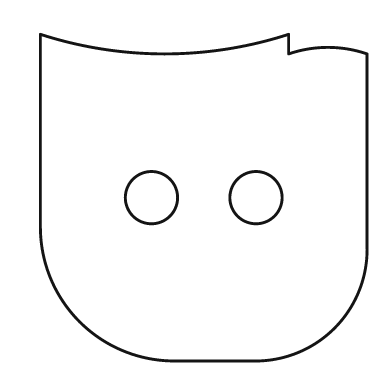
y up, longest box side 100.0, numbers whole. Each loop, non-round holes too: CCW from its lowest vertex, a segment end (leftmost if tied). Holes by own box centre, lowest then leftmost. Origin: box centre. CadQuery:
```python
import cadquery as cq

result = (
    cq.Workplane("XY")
    .moveTo(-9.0, -50.0)
    .lineTo(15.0, -50.0)
    .threePointArc((40.0, -40.0), (50.0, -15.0))
    .lineTo(50.0, 44.0)
    .threePointArc((38.0, 46.0), (26.0, 44.0))
    .lineTo(26.0, 50.0)
    .threePointArc((-12.0, 44.0), (-50.0, 50.0))
    .lineTo(-50.0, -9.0)
    .threePointArc((-38.0, -38.0), (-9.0, -50.0))
    .close()
    .moveTo(-16.0, 0.0)
    .circle(8.0)
    .moveTo(16.0, 0.0)
    .circle(8.0)
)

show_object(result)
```